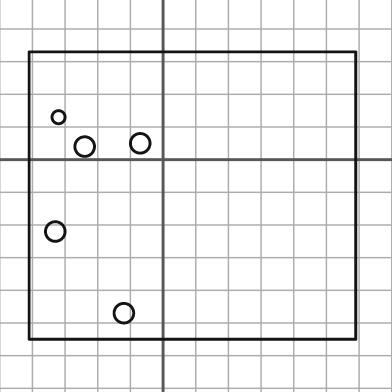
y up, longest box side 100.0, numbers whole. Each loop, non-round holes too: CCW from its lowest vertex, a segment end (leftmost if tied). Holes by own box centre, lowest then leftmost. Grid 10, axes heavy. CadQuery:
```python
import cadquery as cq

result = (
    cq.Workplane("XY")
    .moveTo(-41.0, -55.0)
    .lineTo(59.0, -55.0)
    .lineTo(59.0, 33.0)
    .lineTo(-41.0, 33.0)
    .close()
    .moveTo(-12.0, -47.0)
    .circle(3.0)
    .moveTo(-33.0, -22.0)
    .circle(3.0)
    .moveTo(-24.0, 4.0)
    .circle(3.0)
    .moveTo(-7.0, 5.0)
    .circle(3.0)
    .moveTo(-32.0, 13.0)
    .circle(2.0)
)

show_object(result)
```